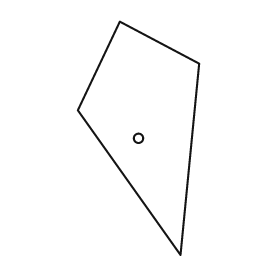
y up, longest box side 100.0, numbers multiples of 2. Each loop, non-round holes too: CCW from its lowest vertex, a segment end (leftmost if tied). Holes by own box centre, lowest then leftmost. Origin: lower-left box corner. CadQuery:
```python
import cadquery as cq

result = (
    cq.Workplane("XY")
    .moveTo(44.0, 0.0)
    .lineTo(52.0, 82.0)
    .lineTo(18.0, 100.0)
    .lineTo(0.0, 62.0)
    .close()
    .moveTo(26.0, 50.0)
    .circle(2.0)
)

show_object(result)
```